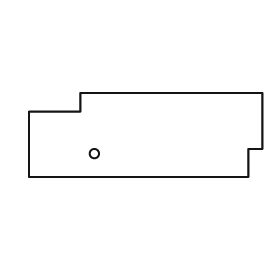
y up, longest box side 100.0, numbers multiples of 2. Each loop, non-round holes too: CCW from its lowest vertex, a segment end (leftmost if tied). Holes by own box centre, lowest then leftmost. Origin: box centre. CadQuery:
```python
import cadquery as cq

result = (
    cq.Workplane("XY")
    .moveTo(-50.0, -18.0)
    .lineTo(44.0, -18.0)
    .lineTo(44.0, -6.0)
    .lineTo(50.0, -6.0)
    .lineTo(50.0, 18.0)
    .lineTo(-28.0, 18.0)
    .lineTo(-28.0, 10.0)
    .lineTo(-50.0, 10.0)
    .close()
    .moveTo(-22.0, -8.0)
    .circle(2.0)
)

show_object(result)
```